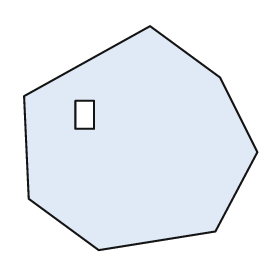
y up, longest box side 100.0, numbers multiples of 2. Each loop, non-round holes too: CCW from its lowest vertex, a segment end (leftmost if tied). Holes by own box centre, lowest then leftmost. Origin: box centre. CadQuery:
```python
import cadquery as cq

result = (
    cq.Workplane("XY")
    .moveTo(-18.0, -48.0)
    .lineTo(32.0, -40.0)
    .lineTo(50.0, -6.0)
    .lineTo(34.0, 26.0)
    .lineTo(4.0, 48.0)
    .lineTo(-50.0, 18.0)
    .lineTo(-48.0, -26.0)
    .close()
    .moveTo(-28.0, 4.0)
    .lineTo(-20.0, 4.0)
    .lineTo(-20.0, 16.0)
    .lineTo(-28.0, 16.0)
    .close()
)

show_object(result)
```